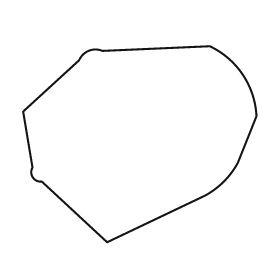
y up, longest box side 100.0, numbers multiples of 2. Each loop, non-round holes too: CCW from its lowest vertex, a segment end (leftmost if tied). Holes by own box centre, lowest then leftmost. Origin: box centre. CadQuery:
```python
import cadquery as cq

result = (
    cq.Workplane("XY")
    .moveTo(-14.0, -42.0)
    .lineTo(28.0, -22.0)
    .threePointArc((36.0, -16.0), (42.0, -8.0))
    .lineTo(50.0, 12.0)
    .threePointArc((44.0, 30.0), (30.0, 42.0))
    .lineTo(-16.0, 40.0)
    .threePointArc((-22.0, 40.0), (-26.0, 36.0))
    .lineTo(-50.0, 14.0)
    .lineTo(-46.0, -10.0)
    .threePointArc((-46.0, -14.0), (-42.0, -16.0))
    .close()
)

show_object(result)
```